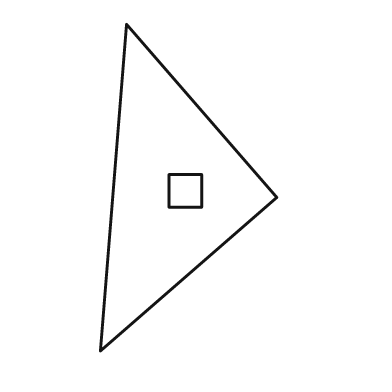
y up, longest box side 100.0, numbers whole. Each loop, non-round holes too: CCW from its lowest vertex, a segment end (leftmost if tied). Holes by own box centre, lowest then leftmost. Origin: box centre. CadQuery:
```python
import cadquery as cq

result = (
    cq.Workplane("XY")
    .moveTo(-27.0, -50.0)
    .lineTo(27.0, -3.0)
    .lineTo(-19.0, 50.0)
    .close()
    .moveTo(-6.0, -6.0)
    .lineTo(4.0, -6.0)
    .lineTo(4.0, 4.0)
    .lineTo(-6.0, 4.0)
    .close()
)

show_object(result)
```